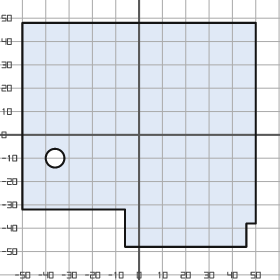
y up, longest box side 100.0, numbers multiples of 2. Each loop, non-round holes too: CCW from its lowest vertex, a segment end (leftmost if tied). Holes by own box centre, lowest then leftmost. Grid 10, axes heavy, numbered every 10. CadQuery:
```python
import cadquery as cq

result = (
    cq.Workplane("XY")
    .moveTo(-6.0, -48.0)
    .lineTo(46.0, -48.0)
    .lineTo(46.0, -38.0)
    .lineTo(50.0, -38.0)
    .lineTo(50.0, 48.0)
    .lineTo(-50.0, 48.0)
    .lineTo(-50.0, -32.0)
    .lineTo(-6.0, -32.0)
    .close()
    .moveTo(-36.0, -10.0)
    .circle(4.0)
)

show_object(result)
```